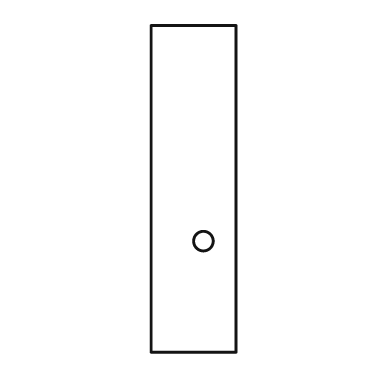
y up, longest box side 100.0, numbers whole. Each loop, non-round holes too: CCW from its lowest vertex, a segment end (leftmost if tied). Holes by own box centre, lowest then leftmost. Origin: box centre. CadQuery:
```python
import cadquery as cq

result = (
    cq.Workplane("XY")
    .moveTo(-13.0, -50.0)
    .lineTo(13.0, -50.0)
    .lineTo(13.0, 50.0)
    .lineTo(-13.0, 50.0)
    .close()
    .moveTo(3.0, -16.0)
    .circle(3.0)
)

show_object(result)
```